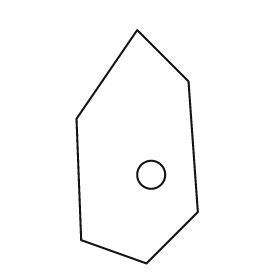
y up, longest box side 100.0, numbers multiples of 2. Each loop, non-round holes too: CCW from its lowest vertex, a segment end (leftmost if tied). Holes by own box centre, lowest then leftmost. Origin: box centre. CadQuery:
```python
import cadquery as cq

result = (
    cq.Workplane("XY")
    .moveTo(4.0, -50.0)
    .lineTo(26.0, -28.0)
    .lineTo(22.0, 28.0)
    .lineTo(0.0, 50.0)
    .lineTo(-26.0, 12.0)
    .lineTo(-24.0, -40.0)
    .close()
    .moveTo(6.0, -12.0)
    .circle(6.0)
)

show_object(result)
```